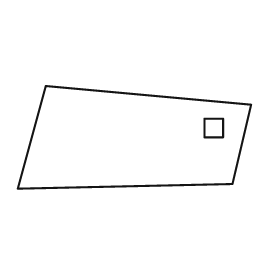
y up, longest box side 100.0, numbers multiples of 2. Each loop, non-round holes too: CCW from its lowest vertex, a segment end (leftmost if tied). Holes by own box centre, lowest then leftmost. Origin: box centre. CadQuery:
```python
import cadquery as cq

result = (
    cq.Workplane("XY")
    .moveTo(-50.0, -22.0)
    .lineTo(42.0, -20.0)
    .lineTo(50.0, 14.0)
    .lineTo(-38.0, 22.0)
    .close()
    .moveTo(30.0, 0.0)
    .lineTo(38.0, 0.0)
    .lineTo(38.0, 8.0)
    .lineTo(30.0, 8.0)
    .close()
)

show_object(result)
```